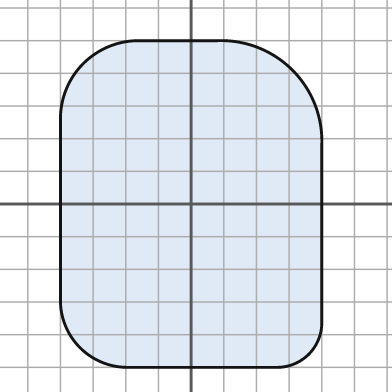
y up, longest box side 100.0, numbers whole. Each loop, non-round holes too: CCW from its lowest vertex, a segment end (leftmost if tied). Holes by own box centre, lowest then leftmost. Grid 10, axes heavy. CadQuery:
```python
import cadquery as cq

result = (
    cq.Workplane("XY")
    .moveTo(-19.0, -50.0)
    .lineTo(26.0, -50.0)
    .threePointArc((36.0, -46.0), (40.0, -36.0))
    .lineTo(40.0, 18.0)
    .threePointArc((31.0, 41.0), (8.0, 50.0))
    .lineTo(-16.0, 50.0)
    .threePointArc((-33.0, 43.0), (-40.0, 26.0))
    .lineTo(-40.0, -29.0)
    .threePointArc((-34.0, -44.0), (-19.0, -50.0))
    .close()
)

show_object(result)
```